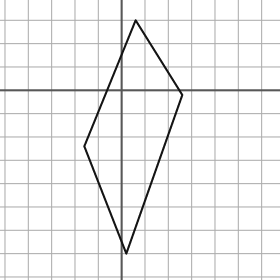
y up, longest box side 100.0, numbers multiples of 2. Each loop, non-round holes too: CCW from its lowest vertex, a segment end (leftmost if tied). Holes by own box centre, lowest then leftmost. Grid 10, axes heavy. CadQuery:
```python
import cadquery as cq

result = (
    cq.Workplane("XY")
    .moveTo(2.0, -70.0)
    .lineTo(26.0, -2.0)
    .lineTo(6.0, 30.0)
    .lineTo(-16.0, -24.0)
    .close()
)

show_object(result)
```